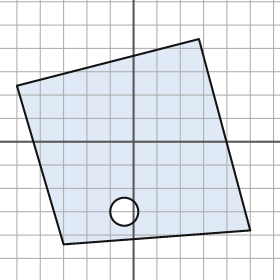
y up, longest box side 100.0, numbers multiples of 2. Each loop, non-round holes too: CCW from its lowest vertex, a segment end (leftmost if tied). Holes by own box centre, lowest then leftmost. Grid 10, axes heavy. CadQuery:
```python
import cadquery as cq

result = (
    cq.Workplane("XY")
    .moveTo(-30.0, -44.0)
    .lineTo(50.0, -38.0)
    .lineTo(28.0, 44.0)
    .lineTo(-50.0, 24.0)
    .close()
    .moveTo(-4.0, -30.0)
    .circle(6.0)
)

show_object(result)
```